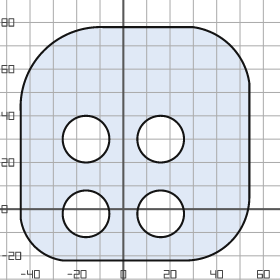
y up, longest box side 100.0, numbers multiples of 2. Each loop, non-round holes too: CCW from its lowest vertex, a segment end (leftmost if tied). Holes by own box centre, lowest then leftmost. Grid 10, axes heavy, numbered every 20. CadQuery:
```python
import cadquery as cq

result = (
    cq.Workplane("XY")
    .moveTo(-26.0, -22.0)
    .lineTo(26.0, -22.0)
    .threePointArc((46.0, -14.0), (54.0, 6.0))
    .lineTo(54.0, 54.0)
    .threePointArc((46.0, 70.0), (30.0, 78.0))
    .lineTo(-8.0, 78.0)
    .threePointArc((-34.0, 68.0), (-44.0, 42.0))
    .lineTo(-44.0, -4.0)
    .threePointArc((-38.0, -16.0), (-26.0, -22.0))
    .close()
    .moveTo(-16.0, -2.0)
    .circle(10.0)
    .moveTo(16.0, -2.0)
    .circle(10.0)
    .moveTo(-16.0, 30.0)
    .circle(10.0)
    .moveTo(16.0, 30.0)
    .circle(10.0)
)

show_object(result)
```